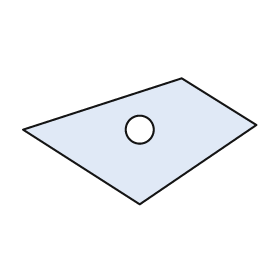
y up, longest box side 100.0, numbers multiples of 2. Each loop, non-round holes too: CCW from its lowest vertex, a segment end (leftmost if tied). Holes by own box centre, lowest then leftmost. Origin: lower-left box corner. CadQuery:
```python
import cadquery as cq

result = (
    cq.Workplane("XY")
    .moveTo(50.0, 0.0)
    .lineTo(100.0, 34.0)
    .lineTo(68.0, 54.0)
    .lineTo(0.0, 32.0)
    .close()
    .moveTo(50.0, 32.0)
    .circle(6.0)
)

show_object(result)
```